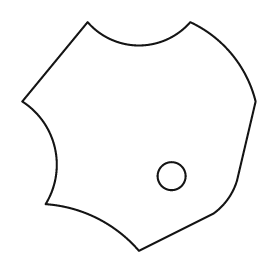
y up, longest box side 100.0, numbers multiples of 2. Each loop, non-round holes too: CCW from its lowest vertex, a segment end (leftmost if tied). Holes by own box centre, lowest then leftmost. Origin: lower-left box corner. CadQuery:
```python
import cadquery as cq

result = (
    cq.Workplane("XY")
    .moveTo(50.0, 0.0)
    .lineTo(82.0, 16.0)
    .threePointArc((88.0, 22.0), (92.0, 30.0))
    .lineTo(100.0, 64.0)
    .threePointArc((90.0, 84.0), (72.0, 98.0))
    .threePointArc((50.0, 88.0), (28.0, 98.0))
    .lineTo(0.0, 64.0)
    .threePointArc((14.0, 44.0), (10.0, 20.0))
    .threePointArc((32.0, 14.0), (50.0, 0.0))
    .close()
    .moveTo(64.0, 32.0)
    .circle(6.0)
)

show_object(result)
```